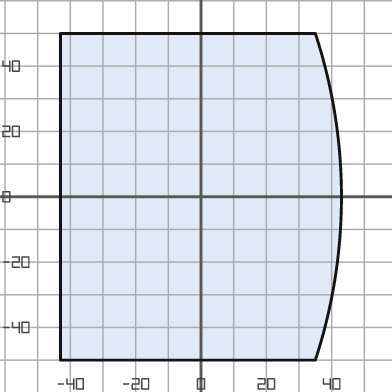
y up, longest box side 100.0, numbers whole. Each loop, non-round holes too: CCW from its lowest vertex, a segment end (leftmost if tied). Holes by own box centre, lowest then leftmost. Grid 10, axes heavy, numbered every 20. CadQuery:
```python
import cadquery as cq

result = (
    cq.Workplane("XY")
    .moveTo(-43.0, -50.0)
    .lineTo(35.0, -50.0)
    .threePointArc((43.0, 0.0), (35.0, 50.0))
    .lineTo(-43.0, 50.0)
    .close()
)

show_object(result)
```